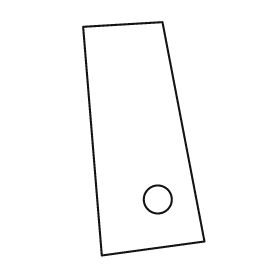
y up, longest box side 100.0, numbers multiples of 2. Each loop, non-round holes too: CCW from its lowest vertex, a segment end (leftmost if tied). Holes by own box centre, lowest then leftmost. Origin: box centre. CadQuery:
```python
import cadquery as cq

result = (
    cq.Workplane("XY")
    .moveTo(-18.0, -50.0)
    .lineTo(26.0, -44.0)
    .lineTo(8.0, 50.0)
    .lineTo(-26.0, 48.0)
    .close()
    .moveTo(6.0, -26.0)
    .circle(6.0)
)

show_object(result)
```